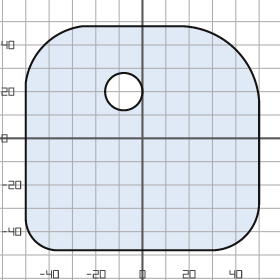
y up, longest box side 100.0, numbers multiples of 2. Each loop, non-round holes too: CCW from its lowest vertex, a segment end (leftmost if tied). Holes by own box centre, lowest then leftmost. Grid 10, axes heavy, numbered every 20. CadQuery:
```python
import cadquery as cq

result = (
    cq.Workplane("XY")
    .moveTo(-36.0, -48.0)
    .lineTo(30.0, -48.0)
    .threePointArc((44.0, -42.0), (50.0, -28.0))
    .lineTo(50.0, 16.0)
    .threePointArc((40.0, 38.0), (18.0, 48.0))
    .lineTo(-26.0, 48.0)
    .threePointArc((-42.0, 40.0), (-50.0, 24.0))
    .lineTo(-50.0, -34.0)
    .threePointArc((-46.0, -44.0), (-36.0, -48.0))
    .close()
    .moveTo(-8.0, 20.0)
    .circle(8.0)
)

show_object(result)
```